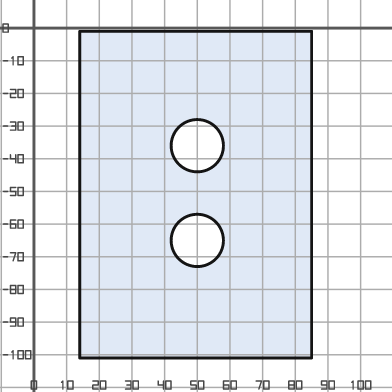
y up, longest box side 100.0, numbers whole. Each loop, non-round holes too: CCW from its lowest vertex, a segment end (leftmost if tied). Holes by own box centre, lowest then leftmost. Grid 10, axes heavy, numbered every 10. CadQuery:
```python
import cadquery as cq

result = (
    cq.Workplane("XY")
    .moveTo(14.0, -101.0)
    .lineTo(85.0, -101.0)
    .lineTo(85.0, -1.0)
    .lineTo(14.0, -1.0)
    .close()
    .moveTo(50.0, -65.0)
    .circle(8.0)
    .moveTo(50.0, -36.0)
    .circle(8.0)
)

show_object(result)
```